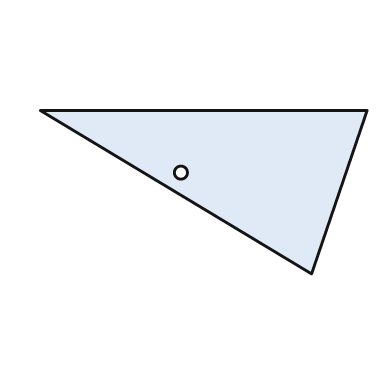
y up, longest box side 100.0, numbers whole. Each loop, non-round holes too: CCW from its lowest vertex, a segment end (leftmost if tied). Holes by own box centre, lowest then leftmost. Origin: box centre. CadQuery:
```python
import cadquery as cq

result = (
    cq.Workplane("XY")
    .moveTo(33.0, -25.0)
    .lineTo(50.0, 25.0)
    .lineTo(-50.0, 25.0)
    .close()
    .moveTo(-7.0, 6.0)
    .circle(2.0)
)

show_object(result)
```